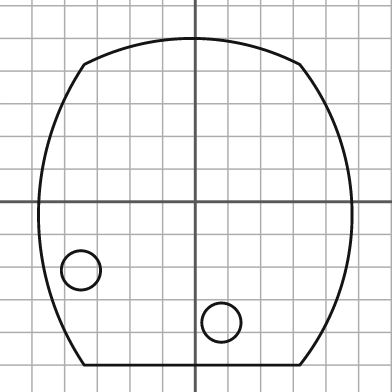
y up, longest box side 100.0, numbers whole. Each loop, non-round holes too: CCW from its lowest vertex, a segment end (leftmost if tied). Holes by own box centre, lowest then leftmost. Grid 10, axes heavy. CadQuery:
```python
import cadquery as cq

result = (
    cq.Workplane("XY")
    .moveTo(-34.0, -50.0)
    .lineTo(32.0, -50.0)
    .threePointArc((48.0, -4.0), (32.0, 42.0))
    .threePointArc((-1.0, 50.0), (-34.0, 42.0))
    .threePointArc((-48.0, -4.0), (-34.0, -50.0))
    .close()
    .moveTo(8.0, -37.0)
    .circle(6.0)
    .moveTo(-35.0, -21.0)
    .circle(6.0)
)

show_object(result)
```